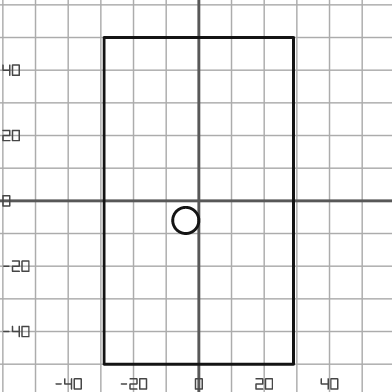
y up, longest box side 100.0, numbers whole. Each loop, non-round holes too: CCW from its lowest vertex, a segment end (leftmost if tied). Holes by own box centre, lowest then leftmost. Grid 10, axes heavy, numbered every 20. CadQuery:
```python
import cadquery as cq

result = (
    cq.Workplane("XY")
    .moveTo(-29.0, -50.0)
    .lineTo(29.0, -50.0)
    .lineTo(29.0, 50.0)
    .lineTo(-29.0, 50.0)
    .close()
    .moveTo(-4.0, -6.0)
    .circle(4.0)
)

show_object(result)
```